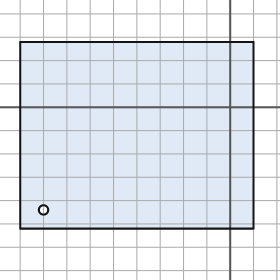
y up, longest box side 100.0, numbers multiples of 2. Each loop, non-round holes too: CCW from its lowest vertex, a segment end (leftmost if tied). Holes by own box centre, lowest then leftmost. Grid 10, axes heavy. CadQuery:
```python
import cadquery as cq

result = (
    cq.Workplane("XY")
    .moveTo(-90.0, -52.0)
    .lineTo(10.0, -52.0)
    .lineTo(10.0, 28.0)
    .lineTo(-90.0, 28.0)
    .close()
    .moveTo(-80.0, -44.0)
    .circle(2.0)
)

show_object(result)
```